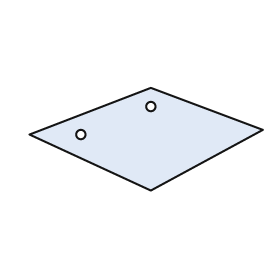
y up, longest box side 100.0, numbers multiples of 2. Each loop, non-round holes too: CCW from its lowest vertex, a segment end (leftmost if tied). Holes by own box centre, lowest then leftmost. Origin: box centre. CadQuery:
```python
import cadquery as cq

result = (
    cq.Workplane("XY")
    .moveTo(2.0, -22.0)
    .lineTo(50.0, 4.0)
    .lineTo(2.0, 22.0)
    .lineTo(-50.0, 2.0)
    .close()
    .moveTo(-28.0, 2.0)
    .circle(2.0)
    .moveTo(2.0, 14.0)
    .circle(2.0)
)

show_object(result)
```